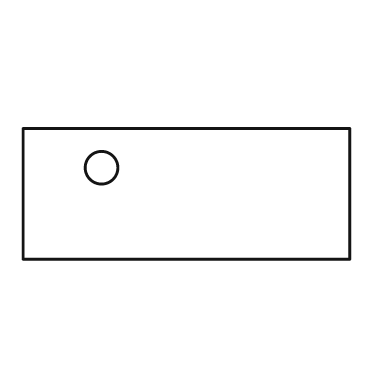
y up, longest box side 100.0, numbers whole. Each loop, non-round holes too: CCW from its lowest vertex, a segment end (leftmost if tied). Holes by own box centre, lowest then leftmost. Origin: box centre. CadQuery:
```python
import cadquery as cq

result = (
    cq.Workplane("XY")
    .moveTo(-50.0, -20.0)
    .lineTo(50.0, -20.0)
    .lineTo(50.0, 20.0)
    .lineTo(-50.0, 20.0)
    .close()
    .moveTo(-26.0, 8.0)
    .circle(5.0)
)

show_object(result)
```